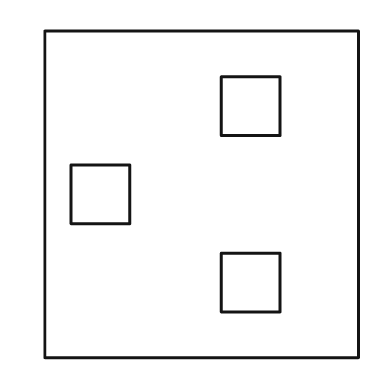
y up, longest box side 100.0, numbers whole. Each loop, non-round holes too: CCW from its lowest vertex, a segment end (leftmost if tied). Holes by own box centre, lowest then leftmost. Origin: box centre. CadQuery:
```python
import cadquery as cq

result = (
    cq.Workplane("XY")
    .moveTo(-48.0, -50.0)
    .lineTo(48.0, -50.0)
    .lineTo(48.0, 50.0)
    .lineTo(-48.0, 50.0)
    .close()
    .moveTo(6.0, -36.0)
    .lineTo(24.0, -36.0)
    .lineTo(24.0, -18.0)
    .lineTo(6.0, -18.0)
    .close()
    .moveTo(-40.0, -9.0)
    .lineTo(-22.0, -9.0)
    .lineTo(-22.0, 9.0)
    .lineTo(-40.0, 9.0)
    .close()
    .moveTo(6.0, 18.0)
    .lineTo(24.0, 18.0)
    .lineTo(24.0, 36.0)
    .lineTo(6.0, 36.0)
    .close()
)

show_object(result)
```